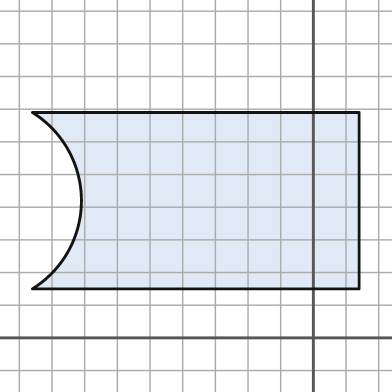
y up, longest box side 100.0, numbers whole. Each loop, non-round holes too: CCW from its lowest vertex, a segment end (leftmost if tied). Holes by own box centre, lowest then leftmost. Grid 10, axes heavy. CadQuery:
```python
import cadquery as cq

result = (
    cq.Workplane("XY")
    .moveTo(-86.0, 15.0)
    .lineTo(14.0, 15.0)
    .lineTo(14.0, 69.0)
    .lineTo(-86.0, 69.0)
    .threePointArc((-71.0, 42.0), (-86.0, 15.0))
    .close()
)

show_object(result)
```